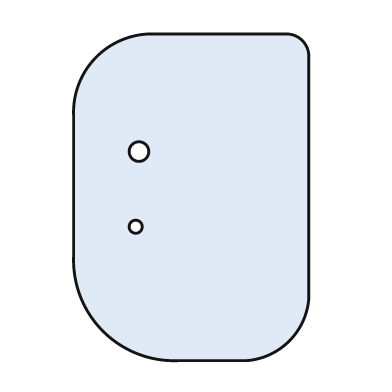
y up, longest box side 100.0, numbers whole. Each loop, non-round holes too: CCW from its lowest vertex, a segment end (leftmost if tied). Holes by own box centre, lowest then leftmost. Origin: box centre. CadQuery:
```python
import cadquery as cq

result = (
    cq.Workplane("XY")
    .moveTo(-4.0, -50.0)
    .lineTo(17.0, -50.0)
    .threePointArc((30.0, -44.0), (36.0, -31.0))
    .lineTo(36.0, 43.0)
    .threePointArc((34.0, 48.0), (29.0, 50.0))
    .lineTo(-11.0, 50.0)
    .threePointArc((-29.0, 43.0), (-36.0, 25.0))
    .lineTo(-36.0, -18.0)
    .threePointArc((-27.0, -41.0), (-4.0, -50.0))
    .close()
    .moveTo(-17.0, -9.0)
    .circle(2.0)
    .moveTo(-16.0, 14.0)
    .circle(3.0)
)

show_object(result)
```